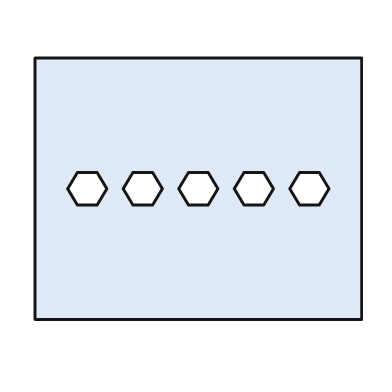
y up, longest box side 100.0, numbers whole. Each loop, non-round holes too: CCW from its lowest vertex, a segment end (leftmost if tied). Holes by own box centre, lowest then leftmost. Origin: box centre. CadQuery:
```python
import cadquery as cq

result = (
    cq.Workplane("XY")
    .moveTo(-50.0, -40.0)
    .lineTo(50.0, -40.0)
    .lineTo(50.0, 40.0)
    .lineTo(-50.0, 40.0)
    .close()
    .moveTo(-37.0, -5.0)
    .lineTo(-31.0, -5.0)
    .lineTo(-28.0, 0.0)
    .lineTo(-31.0, 5.0)
    .lineTo(-37.0, 5.0)
    .lineTo(-40.0, 0.0)
    .close()
    .moveTo(-20.0, -5.0)
    .lineTo(-14.0, -5.0)
    .lineTo(-11.0, 0.0)
    .lineTo(-14.0, 5.0)
    .lineTo(-20.0, 5.0)
    .lineTo(-23.0, 0.0)
    .close()
    .moveTo(-3.0, -5.0)
    .lineTo(3.0, -5.0)
    .lineTo(6.0, 0.0)
    .lineTo(3.0, 5.0)
    .lineTo(-3.0, 5.0)
    .lineTo(-6.0, 0.0)
    .close()
    .moveTo(14.0, -5.0)
    .lineTo(20.0, -5.0)
    .lineTo(23.0, 0.0)
    .lineTo(20.0, 5.0)
    .lineTo(14.0, 5.0)
    .lineTo(11.0, 0.0)
    .close()
    .moveTo(31.0, -5.0)
    .lineTo(37.0, -5.0)
    .lineTo(40.0, 0.0)
    .lineTo(37.0, 5.0)
    .lineTo(31.0, 5.0)
    .lineTo(28.0, 0.0)
    .close()
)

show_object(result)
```